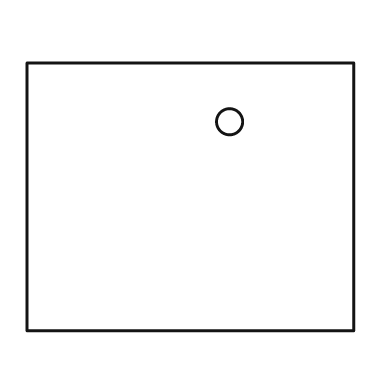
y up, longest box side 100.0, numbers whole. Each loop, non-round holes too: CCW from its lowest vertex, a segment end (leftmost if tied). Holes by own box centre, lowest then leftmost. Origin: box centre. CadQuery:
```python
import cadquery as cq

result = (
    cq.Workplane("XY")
    .moveTo(-50.0, -41.0)
    .lineTo(50.0, -41.0)
    .lineTo(50.0, 41.0)
    .lineTo(-50.0, 41.0)
    .close()
    .moveTo(12.0, 23.0)
    .circle(4.0)
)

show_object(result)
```